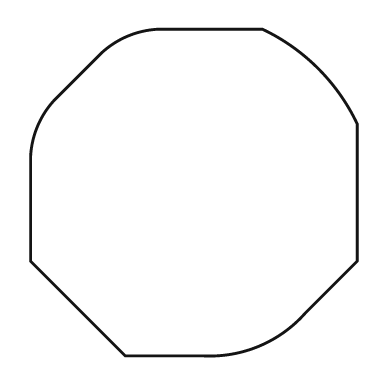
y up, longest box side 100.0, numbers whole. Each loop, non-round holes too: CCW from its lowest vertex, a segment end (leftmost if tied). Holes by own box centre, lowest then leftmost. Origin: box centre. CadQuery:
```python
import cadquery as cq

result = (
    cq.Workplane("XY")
    .moveTo(-21.0, -50.0)
    .lineTo(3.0, -50.0)
    .threePointArc((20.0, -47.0), (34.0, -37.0))
    .lineTo(50.0, -21.0)
    .lineTo(50.0, 21.0)
    .threePointArc((38.0, 38.0), (21.0, 50.0))
    .lineTo(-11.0, 50.0)
    .threePointArc((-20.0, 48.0), (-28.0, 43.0))
    .lineTo(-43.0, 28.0)
    .threePointArc((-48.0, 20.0), (-50.0, 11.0))
    .lineTo(-50.0, -21.0)
    .close()
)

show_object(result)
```